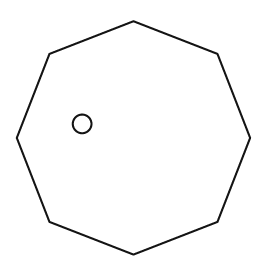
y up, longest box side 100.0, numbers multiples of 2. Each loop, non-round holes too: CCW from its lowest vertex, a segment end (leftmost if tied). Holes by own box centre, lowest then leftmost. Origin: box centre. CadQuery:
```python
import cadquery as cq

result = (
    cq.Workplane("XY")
    .moveTo(0.0, -50.0)
    .lineTo(36.0, -36.0)
    .lineTo(50.0, 0.0)
    .lineTo(36.0, 36.0)
    .lineTo(0.0, 50.0)
    .lineTo(-36.0, 36.0)
    .lineTo(-50.0, 0.0)
    .lineTo(-36.0, -36.0)
    .close()
    .moveTo(-22.0, 6.0)
    .circle(4.0)
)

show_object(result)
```